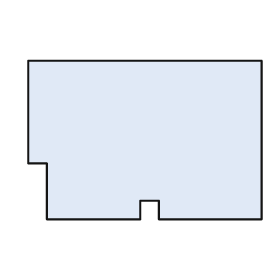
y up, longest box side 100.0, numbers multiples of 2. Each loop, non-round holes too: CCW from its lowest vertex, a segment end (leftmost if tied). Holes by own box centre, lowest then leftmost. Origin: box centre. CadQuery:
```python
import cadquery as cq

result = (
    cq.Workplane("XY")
    .moveTo(-42.0, -34.0)
    .lineTo(-2.0, -34.0)
    .lineTo(-2.0, -26.0)
    .lineTo(6.0, -26.0)
    .lineTo(6.0, -34.0)
    .lineTo(50.0, -34.0)
    .lineTo(50.0, 34.0)
    .lineTo(-50.0, 34.0)
    .lineTo(-50.0, -10.0)
    .lineTo(-42.0, -10.0)
    .close()
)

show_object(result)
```